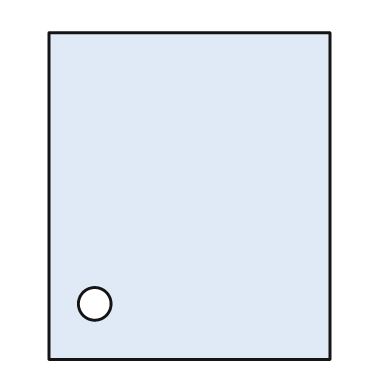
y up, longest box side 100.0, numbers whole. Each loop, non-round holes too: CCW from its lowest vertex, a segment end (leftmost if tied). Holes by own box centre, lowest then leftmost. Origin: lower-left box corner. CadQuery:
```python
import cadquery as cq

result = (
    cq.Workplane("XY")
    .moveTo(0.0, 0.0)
    .lineTo(86.0, 0.0)
    .lineTo(86.0, 100.0)
    .lineTo(0.0, 100.0)
    .close()
    .moveTo(14.0, 17.0)
    .circle(5.0)
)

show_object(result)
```